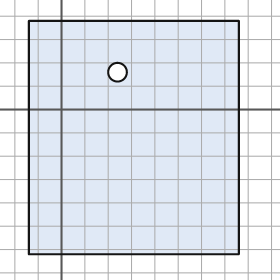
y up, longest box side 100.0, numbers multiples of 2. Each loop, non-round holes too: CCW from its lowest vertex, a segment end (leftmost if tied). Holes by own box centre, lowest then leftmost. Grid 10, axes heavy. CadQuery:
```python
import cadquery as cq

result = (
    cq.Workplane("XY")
    .moveTo(-14.0, -62.0)
    .lineTo(76.0, -62.0)
    .lineTo(76.0, 38.0)
    .lineTo(-14.0, 38.0)
    .close()
    .moveTo(24.0, 16.0)
    .circle(4.0)
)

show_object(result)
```